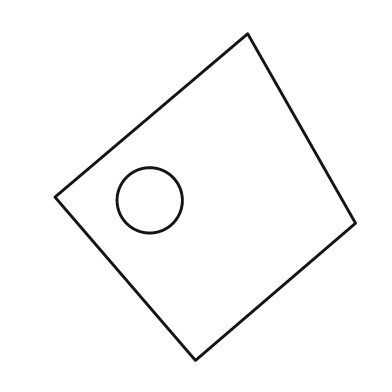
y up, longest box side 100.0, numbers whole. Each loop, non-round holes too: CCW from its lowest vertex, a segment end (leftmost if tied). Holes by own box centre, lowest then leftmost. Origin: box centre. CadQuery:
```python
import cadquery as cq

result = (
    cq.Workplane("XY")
    .moveTo(-3.0, -50.0)
    .lineTo(46.0, -8.0)
    .lineTo(13.0, 50.0)
    .lineTo(-46.0, 0.0)
    .close()
    .moveTo(-17.0, -1.0)
    .circle(10.0)
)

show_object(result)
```